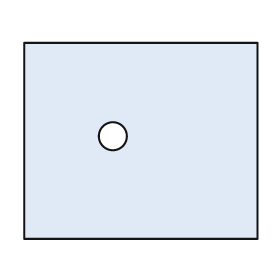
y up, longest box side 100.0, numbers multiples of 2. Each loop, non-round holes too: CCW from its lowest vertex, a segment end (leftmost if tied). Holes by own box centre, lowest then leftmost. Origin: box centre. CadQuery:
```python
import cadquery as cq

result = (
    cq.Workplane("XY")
    .moveTo(-50.0, -42.0)
    .lineTo(50.0, -42.0)
    .lineTo(50.0, 42.0)
    .lineTo(-50.0, 42.0)
    .close()
    .moveTo(-12.0, 2.0)
    .circle(6.0)
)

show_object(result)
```